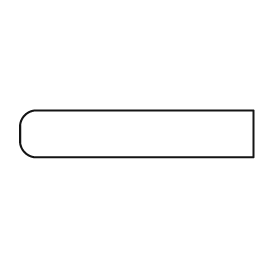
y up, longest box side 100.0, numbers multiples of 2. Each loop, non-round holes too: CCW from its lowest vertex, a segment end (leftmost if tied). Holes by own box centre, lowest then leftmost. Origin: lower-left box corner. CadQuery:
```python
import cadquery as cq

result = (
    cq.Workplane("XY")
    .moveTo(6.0, 0.0)
    .lineTo(100.0, 0.0)
    .lineTo(100.0, 20.0)
    .lineTo(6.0, 20.0)
    .threePointArc((2.0, 18.0), (0.0, 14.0))
    .lineTo(0.0, 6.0)
    .threePointArc((2.0, 2.0), (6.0, 0.0))
    .close()
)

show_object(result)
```